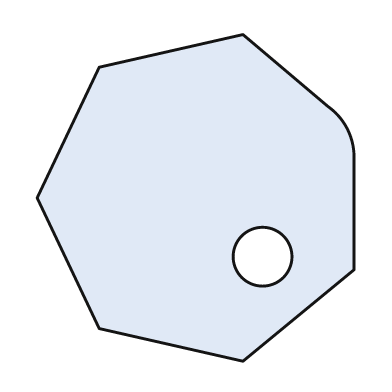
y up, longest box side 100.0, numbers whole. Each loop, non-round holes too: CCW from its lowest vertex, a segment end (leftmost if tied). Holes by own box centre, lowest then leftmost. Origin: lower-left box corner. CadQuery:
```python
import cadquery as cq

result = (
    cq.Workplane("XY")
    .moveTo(63.0, 0.0)
    .lineTo(97.0, 28.0)
    .lineTo(97.0, 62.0)
    .threePointArc((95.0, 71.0), (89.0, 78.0))
    .lineTo(63.0, 100.0)
    .lineTo(19.0, 90.0)
    .lineTo(0.0, 50.0)
    .lineTo(19.0, 10.0)
    .close()
    .moveTo(69.0, 32.0)
    .circle(9.0)
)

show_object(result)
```